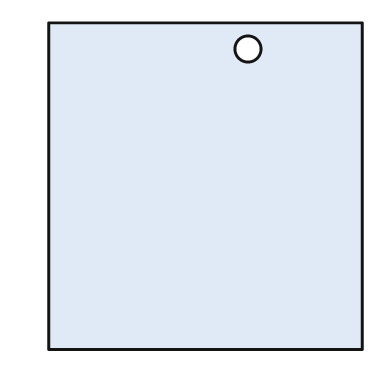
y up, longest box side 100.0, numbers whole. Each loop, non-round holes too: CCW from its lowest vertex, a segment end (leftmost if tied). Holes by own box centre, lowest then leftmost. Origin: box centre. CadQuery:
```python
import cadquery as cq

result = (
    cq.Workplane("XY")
    .moveTo(-48.0, -50.0)
    .lineTo(48.0, -50.0)
    .lineTo(48.0, 50.0)
    .lineTo(-48.0, 50.0)
    .close()
    .moveTo(13.0, 42.0)
    .circle(4.0)
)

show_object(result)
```